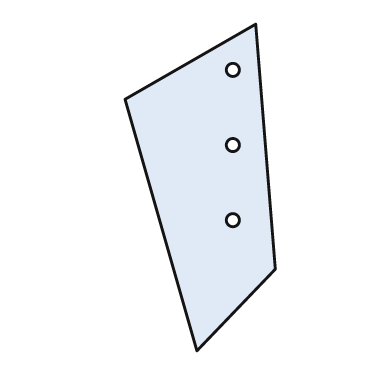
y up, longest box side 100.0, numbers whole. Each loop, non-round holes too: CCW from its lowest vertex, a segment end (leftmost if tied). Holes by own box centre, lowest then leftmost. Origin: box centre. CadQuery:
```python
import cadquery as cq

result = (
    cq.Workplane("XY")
    .moveTo(-1.0, -50.0)
    .lineTo(23.0, -25.0)
    .lineTo(17.0, 50.0)
    .lineTo(-23.0, 27.0)
    .close()
    .moveTo(10.0, -10.0)
    .circle(2.0)
    .moveTo(10.0, 13.0)
    .circle(2.0)
    .moveTo(10.0, 36.0)
    .circle(2.0)
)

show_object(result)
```